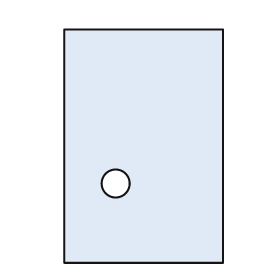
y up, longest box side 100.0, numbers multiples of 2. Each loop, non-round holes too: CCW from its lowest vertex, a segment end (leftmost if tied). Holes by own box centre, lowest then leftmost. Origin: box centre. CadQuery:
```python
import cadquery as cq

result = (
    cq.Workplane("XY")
    .moveTo(-34.0, -50.0)
    .lineTo(34.0, -50.0)
    .lineTo(34.0, 50.0)
    .lineTo(-34.0, 50.0)
    .close()
    .moveTo(-12.0, -16.0)
    .circle(6.0)
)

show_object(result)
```